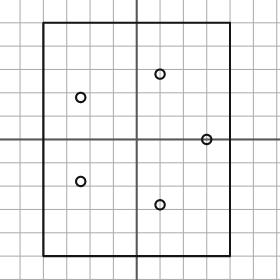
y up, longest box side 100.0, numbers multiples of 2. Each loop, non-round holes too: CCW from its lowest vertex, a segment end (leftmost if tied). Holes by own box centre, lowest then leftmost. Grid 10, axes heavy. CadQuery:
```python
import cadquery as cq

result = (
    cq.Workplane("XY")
    .moveTo(-40.0, -50.0)
    .lineTo(40.0, -50.0)
    .lineTo(40.0, 50.0)
    .lineTo(-40.0, 50.0)
    .close()
    .moveTo(10.0, -28.0)
    .circle(2.0)
    .moveTo(-24.0, -18.0)
    .circle(2.0)
    .moveTo(30.0, 0.0)
    .circle(2.0)
    .moveTo(-24.0, 18.0)
    .circle(2.0)
    .moveTo(10.0, 28.0)
    .circle(2.0)
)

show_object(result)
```